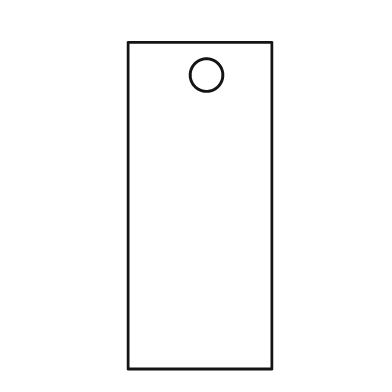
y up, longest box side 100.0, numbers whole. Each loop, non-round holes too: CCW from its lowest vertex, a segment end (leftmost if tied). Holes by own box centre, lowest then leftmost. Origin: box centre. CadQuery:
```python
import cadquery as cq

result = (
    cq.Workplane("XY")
    .moveTo(-22.0, -50.0)
    .lineTo(22.0, -50.0)
    .lineTo(22.0, 50.0)
    .lineTo(-22.0, 50.0)
    .close()
    .moveTo(2.0, 40.0)
    .circle(5.0)
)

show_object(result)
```